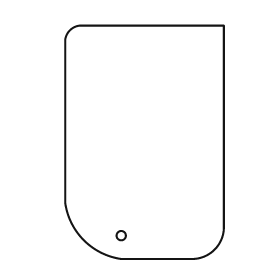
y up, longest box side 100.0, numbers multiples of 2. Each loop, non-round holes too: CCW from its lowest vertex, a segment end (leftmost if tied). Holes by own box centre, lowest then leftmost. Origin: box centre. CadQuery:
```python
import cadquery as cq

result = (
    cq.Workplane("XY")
    .moveTo(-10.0, -50.0)
    .lineTo(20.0, -50.0)
    .threePointArc((30.0, -46.0), (34.0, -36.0))
    .lineTo(34.0, 50.0)
    .lineTo(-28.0, 50.0)
    .threePointArc((-32.0, 48.0), (-34.0, 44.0))
    .lineTo(-34.0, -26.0)
    .threePointArc((-26.0, -42.0), (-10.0, -50.0))
    .close()
    .moveTo(-10.0, -40.0)
    .circle(2.0)
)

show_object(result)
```